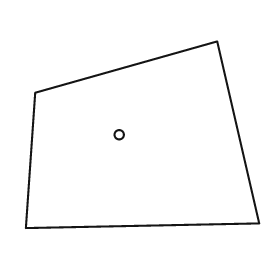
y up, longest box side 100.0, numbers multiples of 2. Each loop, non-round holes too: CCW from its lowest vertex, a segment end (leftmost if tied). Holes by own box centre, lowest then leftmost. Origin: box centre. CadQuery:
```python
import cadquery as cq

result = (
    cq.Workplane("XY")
    .moveTo(-50.0, -40.0)
    .lineTo(50.0, -38.0)
    .lineTo(32.0, 40.0)
    .lineTo(-46.0, 18.0)
    .close()
    .moveTo(-10.0, 0.0)
    .circle(2.0)
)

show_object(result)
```